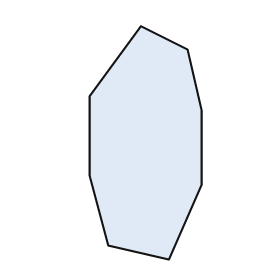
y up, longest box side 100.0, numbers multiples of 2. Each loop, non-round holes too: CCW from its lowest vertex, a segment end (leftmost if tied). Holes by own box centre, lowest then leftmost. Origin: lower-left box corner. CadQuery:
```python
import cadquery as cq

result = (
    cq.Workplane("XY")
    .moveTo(34.0, 0.0)
    .lineTo(48.0, 32.0)
    .lineTo(48.0, 64.0)
    .lineTo(42.0, 90.0)
    .lineTo(22.0, 100.0)
    .lineTo(0.0, 70.0)
    .lineTo(0.0, 36.0)
    .lineTo(8.0, 6.0)
    .close()
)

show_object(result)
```